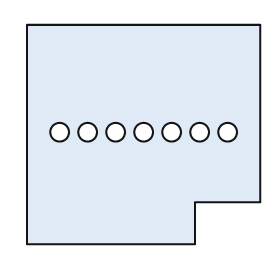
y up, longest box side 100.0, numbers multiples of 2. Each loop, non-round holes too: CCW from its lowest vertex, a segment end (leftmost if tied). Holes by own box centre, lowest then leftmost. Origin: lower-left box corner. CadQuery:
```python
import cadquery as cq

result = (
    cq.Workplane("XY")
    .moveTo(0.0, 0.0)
    .lineTo(72.0, 0.0)
    .lineTo(72.0, 18.0)
    .lineTo(100.0, 18.0)
    .lineTo(100.0, 94.0)
    .lineTo(0.0, 94.0)
    .close()
    .moveTo(14.0, 48.0)
    .circle(4.0)
    .moveTo(26.0, 48.0)
    .circle(4.0)
    .moveTo(38.0, 48.0)
    .circle(4.0)
    .moveTo(50.0, 48.0)
    .circle(4.0)
    .moveTo(62.0, 48.0)
    .circle(4.0)
    .moveTo(74.0, 48.0)
    .circle(4.0)
    .moveTo(86.0, 48.0)
    .circle(4.0)
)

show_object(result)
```